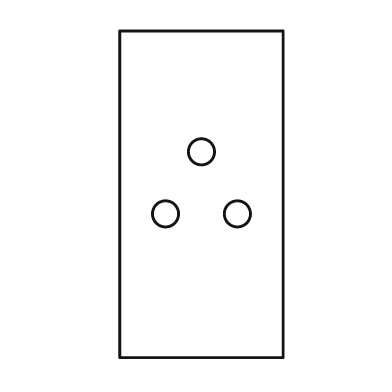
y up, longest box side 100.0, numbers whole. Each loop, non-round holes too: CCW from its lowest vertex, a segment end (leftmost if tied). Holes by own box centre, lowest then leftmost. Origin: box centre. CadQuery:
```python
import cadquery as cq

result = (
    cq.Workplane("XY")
    .moveTo(-25.0, -50.0)
    .lineTo(25.0, -50.0)
    .lineTo(25.0, 50.0)
    .lineTo(-25.0, 50.0)
    .close()
    .moveTo(-11.0, -6.0)
    .circle(4.0)
    .moveTo(11.0, -6.0)
    .circle(4.0)
    .moveTo(0.0, 13.0)
    .circle(4.0)
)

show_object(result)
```